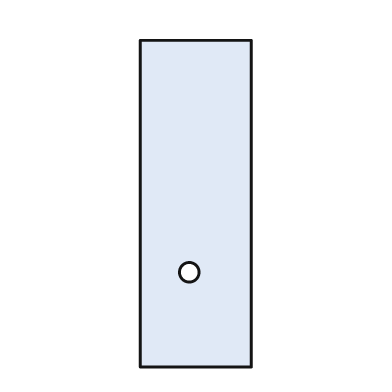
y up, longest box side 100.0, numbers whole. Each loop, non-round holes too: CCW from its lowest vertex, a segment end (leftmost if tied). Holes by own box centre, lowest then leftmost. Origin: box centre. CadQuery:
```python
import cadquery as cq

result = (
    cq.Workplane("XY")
    .moveTo(-17.0, -50.0)
    .lineTo(17.0, -50.0)
    .lineTo(17.0, 50.0)
    .lineTo(-17.0, 50.0)
    .close()
    .moveTo(-2.0, -21.0)
    .circle(3.0)
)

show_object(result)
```